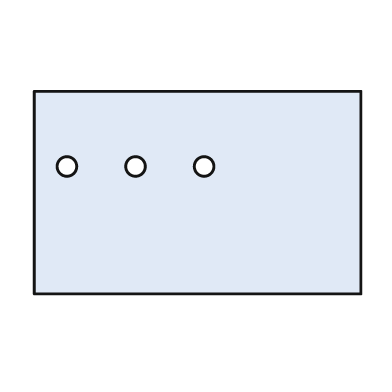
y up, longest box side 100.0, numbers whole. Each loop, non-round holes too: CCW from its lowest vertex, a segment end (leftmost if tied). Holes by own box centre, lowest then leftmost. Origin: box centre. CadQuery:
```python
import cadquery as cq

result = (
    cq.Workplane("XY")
    .moveTo(-50.0, -31.0)
    .lineTo(50.0, -31.0)
    .lineTo(50.0, 31.0)
    .lineTo(-50.0, 31.0)
    .close()
    .moveTo(-40.0, 8.0)
    .circle(3.0)
    .moveTo(-19.0, 8.0)
    .circle(3.0)
    .moveTo(2.0, 8.0)
    .circle(3.0)
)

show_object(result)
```